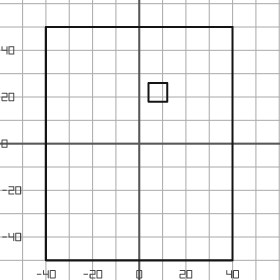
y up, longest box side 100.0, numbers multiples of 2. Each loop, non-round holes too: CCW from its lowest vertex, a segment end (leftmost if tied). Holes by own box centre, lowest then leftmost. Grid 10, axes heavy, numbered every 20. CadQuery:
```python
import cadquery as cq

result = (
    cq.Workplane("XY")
    .moveTo(-40.0, -50.0)
    .lineTo(40.0, -50.0)
    .lineTo(40.0, 50.0)
    .lineTo(-40.0, 50.0)
    .close()
    .moveTo(4.0, 18.0)
    .lineTo(12.0, 18.0)
    .lineTo(12.0, 26.0)
    .lineTo(4.0, 26.0)
    .close()
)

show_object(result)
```